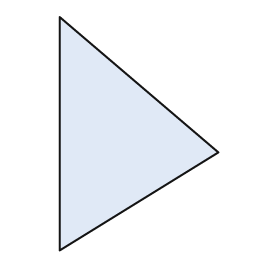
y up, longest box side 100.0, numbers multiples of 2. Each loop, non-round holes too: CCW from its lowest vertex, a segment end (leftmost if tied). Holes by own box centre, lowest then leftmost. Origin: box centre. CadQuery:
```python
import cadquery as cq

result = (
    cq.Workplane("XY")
    .moveTo(-34.0, -50.0)
    .lineTo(34.0, -8.0)
    .lineTo(-34.0, 50.0)
    .close()
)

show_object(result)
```